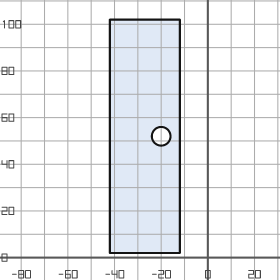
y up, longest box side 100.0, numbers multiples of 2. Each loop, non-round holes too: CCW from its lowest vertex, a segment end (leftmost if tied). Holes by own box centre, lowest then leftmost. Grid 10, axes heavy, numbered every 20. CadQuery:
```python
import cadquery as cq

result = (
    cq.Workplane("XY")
    .moveTo(-42.0, 2.0)
    .lineTo(-12.0, 2.0)
    .lineTo(-12.0, 102.0)
    .lineTo(-42.0, 102.0)
    .close()
    .moveTo(-20.0, 52.0)
    .circle(4.0)
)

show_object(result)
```